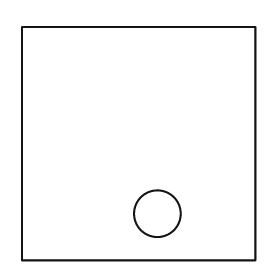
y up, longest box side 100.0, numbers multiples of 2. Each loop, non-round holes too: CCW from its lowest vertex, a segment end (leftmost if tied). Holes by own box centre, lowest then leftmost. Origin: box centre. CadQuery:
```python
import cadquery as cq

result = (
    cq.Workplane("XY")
    .moveTo(-50.0, -50.0)
    .lineTo(50.0, -50.0)
    .lineTo(50.0, 50.0)
    .lineTo(-50.0, 50.0)
    .close()
    .moveTo(8.0, -30.0)
    .circle(10.0)
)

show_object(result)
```